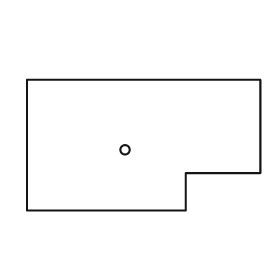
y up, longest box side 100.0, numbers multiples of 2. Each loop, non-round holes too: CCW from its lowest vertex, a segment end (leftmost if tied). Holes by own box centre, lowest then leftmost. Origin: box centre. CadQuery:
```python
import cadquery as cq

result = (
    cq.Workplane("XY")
    .moveTo(-50.0, -28.0)
    .lineTo(18.0, -28.0)
    .lineTo(18.0, -12.0)
    .lineTo(50.0, -12.0)
    .lineTo(50.0, 28.0)
    .lineTo(-50.0, 28.0)
    .close()
    .moveTo(-8.0, -2.0)
    .circle(2.0)
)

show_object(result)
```